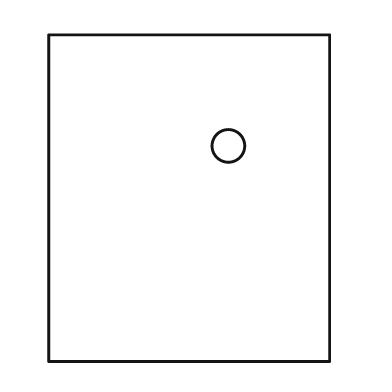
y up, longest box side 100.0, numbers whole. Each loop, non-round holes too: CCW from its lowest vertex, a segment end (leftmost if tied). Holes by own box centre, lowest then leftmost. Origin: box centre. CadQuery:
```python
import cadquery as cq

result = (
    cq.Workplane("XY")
    .moveTo(-43.0, -50.0)
    .lineTo(43.0, -50.0)
    .lineTo(43.0, 50.0)
    .lineTo(-43.0, 50.0)
    .close()
    .moveTo(12.0, 16.0)
    .circle(5.0)
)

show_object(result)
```